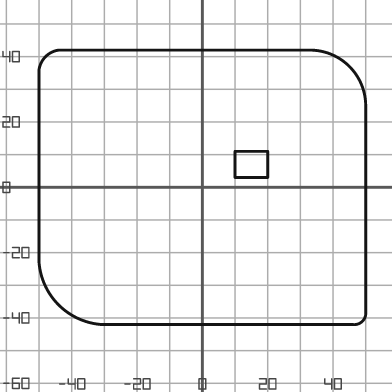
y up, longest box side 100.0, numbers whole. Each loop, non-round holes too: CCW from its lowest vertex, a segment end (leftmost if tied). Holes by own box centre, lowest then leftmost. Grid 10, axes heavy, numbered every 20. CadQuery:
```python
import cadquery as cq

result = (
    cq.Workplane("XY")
    .moveTo(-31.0, -42.0)
    .lineTo(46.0, -42.0)
    .threePointArc((49.0, -41.0), (50.0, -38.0))
    .lineTo(50.0, 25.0)
    .threePointArc((45.0, 37.0), (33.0, 42.0))
    .lineTo(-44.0, 42.0)
    .threePointArc((-48.0, 40.0), (-50.0, 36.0))
    .lineTo(-50.0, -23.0)
    .threePointArc((-44.0, -36.0), (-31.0, -42.0))
    .close()
    .moveTo(10.0, 3.0)
    .lineTo(20.0, 3.0)
    .lineTo(20.0, 11.0)
    .lineTo(10.0, 11.0)
    .close()
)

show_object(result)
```